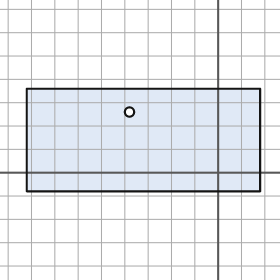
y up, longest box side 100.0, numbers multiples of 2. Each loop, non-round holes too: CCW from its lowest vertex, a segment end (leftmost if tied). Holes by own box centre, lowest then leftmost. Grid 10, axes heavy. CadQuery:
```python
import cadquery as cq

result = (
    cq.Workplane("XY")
    .moveTo(-82.0, -8.0)
    .lineTo(18.0, -8.0)
    .lineTo(18.0, 36.0)
    .lineTo(-82.0, 36.0)
    .close()
    .moveTo(-38.0, 26.0)
    .circle(2.0)
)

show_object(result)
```